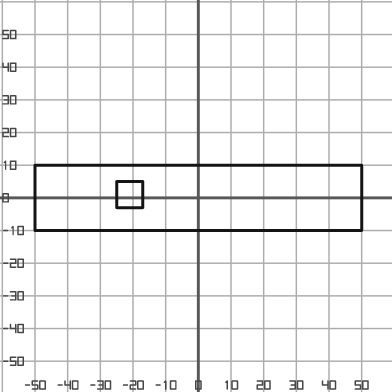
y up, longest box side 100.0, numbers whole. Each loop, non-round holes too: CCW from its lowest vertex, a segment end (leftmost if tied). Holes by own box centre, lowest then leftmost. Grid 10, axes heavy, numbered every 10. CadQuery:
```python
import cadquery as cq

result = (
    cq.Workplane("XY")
    .moveTo(-50.0, -10.0)
    .lineTo(50.0, -10.0)
    .lineTo(50.0, 10.0)
    .lineTo(-50.0, 10.0)
    .close()
    .moveTo(-25.0, -3.0)
    .lineTo(-17.0, -3.0)
    .lineTo(-17.0, 5.0)
    .lineTo(-25.0, 5.0)
    .close()
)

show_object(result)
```